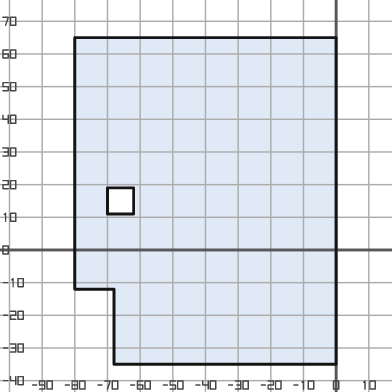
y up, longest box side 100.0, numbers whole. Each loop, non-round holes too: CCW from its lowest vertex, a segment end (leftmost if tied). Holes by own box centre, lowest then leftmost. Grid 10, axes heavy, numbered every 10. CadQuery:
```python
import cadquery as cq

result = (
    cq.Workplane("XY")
    .moveTo(-68.0, -35.0)
    .lineTo(0.0, -35.0)
    .lineTo(0.0, 65.0)
    .lineTo(-80.0, 65.0)
    .lineTo(-80.0, -12.0)
    .lineTo(-68.0, -12.0)
    .close()
    .moveTo(-70.0, 11.0)
    .lineTo(-62.0, 11.0)
    .lineTo(-62.0, 19.0)
    .lineTo(-70.0, 19.0)
    .close()
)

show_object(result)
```